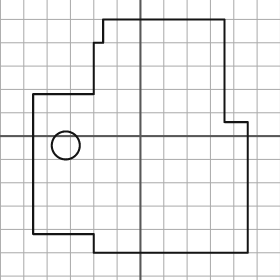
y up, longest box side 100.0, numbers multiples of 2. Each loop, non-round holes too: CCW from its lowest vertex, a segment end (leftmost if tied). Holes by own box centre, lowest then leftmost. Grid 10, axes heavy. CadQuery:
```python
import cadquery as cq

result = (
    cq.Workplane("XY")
    .moveTo(-20.0, -50.0)
    .lineTo(46.0, -50.0)
    .lineTo(46.0, 6.0)
    .lineTo(36.0, 6.0)
    .lineTo(36.0, 50.0)
    .lineTo(-16.0, 50.0)
    .lineTo(-16.0, 40.0)
    .lineTo(-20.0, 40.0)
    .lineTo(-20.0, 18.0)
    .lineTo(-46.0, 18.0)
    .lineTo(-46.0, -42.0)
    .lineTo(-20.0, -42.0)
    .close()
    .moveTo(-32.0, -4.0)
    .circle(6.0)
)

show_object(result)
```